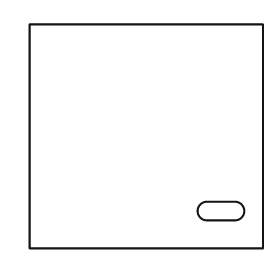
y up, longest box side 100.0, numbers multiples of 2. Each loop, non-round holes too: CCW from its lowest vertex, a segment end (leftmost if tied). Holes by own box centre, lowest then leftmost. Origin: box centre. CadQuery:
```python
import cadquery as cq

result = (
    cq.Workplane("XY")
    .moveTo(-50.0, -48.0)
    .lineTo(50.0, -48.0)
    .lineTo(50.0, 48.0)
    .lineTo(-50.0, 48.0)
    .close()
    .moveTo(26.0, -36.0)
    .lineTo(38.0, -36.0)
    .threePointArc((42.0, -32.0), (38.0, -28.0))
    .lineTo(26.0, -28.0)
    .threePointArc((22.0, -32.0), (26.0, -36.0))
    .close()
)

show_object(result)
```